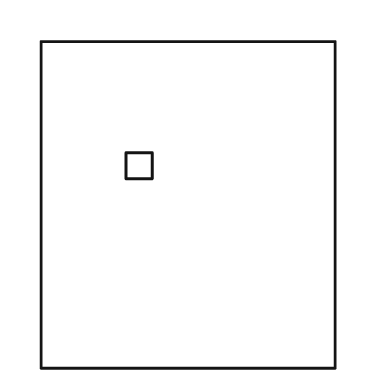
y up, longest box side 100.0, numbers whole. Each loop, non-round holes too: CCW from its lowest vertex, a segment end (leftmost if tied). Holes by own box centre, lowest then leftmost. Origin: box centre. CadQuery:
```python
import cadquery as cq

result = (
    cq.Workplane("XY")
    .moveTo(-45.0, -50.0)
    .lineTo(45.0, -50.0)
    .lineTo(45.0, 50.0)
    .lineTo(-45.0, 50.0)
    .close()
    .moveTo(-19.0, 8.0)
    .lineTo(-11.0, 8.0)
    .lineTo(-11.0, 16.0)
    .lineTo(-19.0, 16.0)
    .close()
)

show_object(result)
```